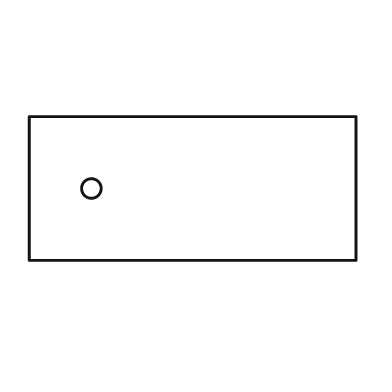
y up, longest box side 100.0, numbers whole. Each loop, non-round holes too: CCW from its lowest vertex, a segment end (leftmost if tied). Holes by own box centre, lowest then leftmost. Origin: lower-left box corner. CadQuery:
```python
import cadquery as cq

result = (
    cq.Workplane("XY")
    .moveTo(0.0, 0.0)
    .lineTo(100.0, 0.0)
    .lineTo(100.0, 44.0)
    .lineTo(0.0, 44.0)
    .close()
    .moveTo(19.0, 22.0)
    .circle(3.0)
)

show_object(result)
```